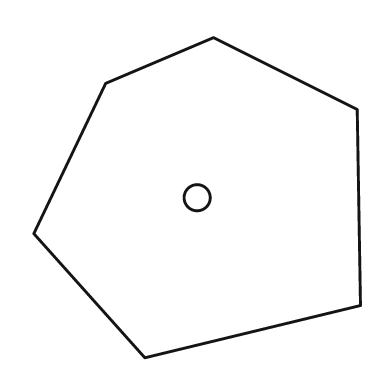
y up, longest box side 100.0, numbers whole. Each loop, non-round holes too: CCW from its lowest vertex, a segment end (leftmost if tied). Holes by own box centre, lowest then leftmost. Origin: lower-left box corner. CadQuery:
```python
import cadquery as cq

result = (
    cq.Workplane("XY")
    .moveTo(34.0, 0.0)
    .lineTo(100.0, 16.0)
    .lineTo(99.0, 76.0)
    .lineTo(55.0, 98.0)
    .lineTo(22.0, 84.0)
    .lineTo(0.0, 38.0)
    .close()
    .moveTo(50.0, 49.0)
    .circle(4.0)
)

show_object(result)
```